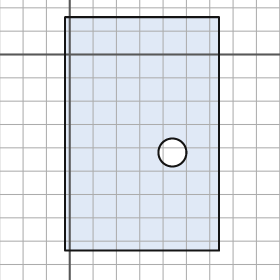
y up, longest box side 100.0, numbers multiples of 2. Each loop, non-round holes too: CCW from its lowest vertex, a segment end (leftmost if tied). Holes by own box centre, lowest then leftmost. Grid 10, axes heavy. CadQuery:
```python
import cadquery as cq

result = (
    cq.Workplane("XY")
    .moveTo(-2.0, -84.0)
    .lineTo(64.0, -84.0)
    .lineTo(64.0, 16.0)
    .lineTo(-2.0, 16.0)
    .close()
    .moveTo(44.0, -42.0)
    .circle(6.0)
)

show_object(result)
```